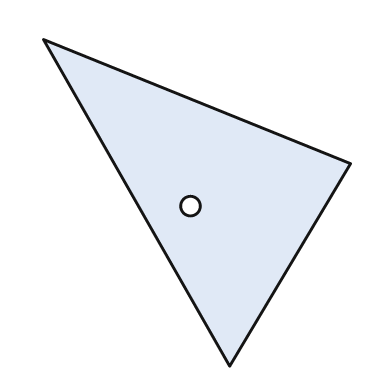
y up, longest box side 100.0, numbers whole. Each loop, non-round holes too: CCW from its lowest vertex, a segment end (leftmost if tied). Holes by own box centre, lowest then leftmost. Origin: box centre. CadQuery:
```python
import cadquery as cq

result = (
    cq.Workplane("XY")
    .moveTo(10.0, -50.0)
    .lineTo(47.0, 12.0)
    .lineTo(-47.0, 50.0)
    .close()
    .moveTo(-2.0, -1.0)
    .circle(3.0)
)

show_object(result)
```